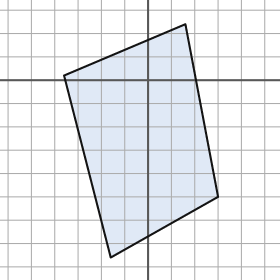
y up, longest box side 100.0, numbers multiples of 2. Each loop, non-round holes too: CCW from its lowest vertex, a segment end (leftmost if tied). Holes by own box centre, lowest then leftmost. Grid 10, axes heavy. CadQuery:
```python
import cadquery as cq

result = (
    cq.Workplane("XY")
    .moveTo(-16.0, -76.0)
    .lineTo(30.0, -50.0)
    .lineTo(16.0, 24.0)
    .lineTo(-36.0, 2.0)
    .close()
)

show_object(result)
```